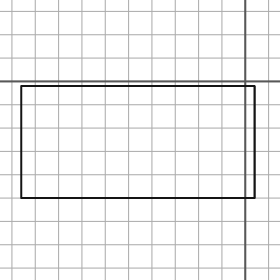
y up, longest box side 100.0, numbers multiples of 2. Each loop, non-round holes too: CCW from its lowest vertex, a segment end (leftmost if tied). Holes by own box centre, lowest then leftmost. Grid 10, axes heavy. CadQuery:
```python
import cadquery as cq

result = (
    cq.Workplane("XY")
    .moveTo(-96.0, -50.0)
    .lineTo(4.0, -50.0)
    .lineTo(4.0, -2.0)
    .lineTo(-96.0, -2.0)
    .close()
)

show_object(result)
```